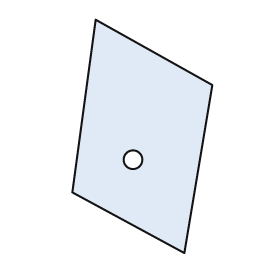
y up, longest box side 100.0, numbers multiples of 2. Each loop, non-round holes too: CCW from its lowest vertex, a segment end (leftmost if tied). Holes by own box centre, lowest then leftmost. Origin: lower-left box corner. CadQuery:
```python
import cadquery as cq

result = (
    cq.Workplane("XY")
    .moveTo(48.0, 0.0)
    .lineTo(60.0, 72.0)
    .lineTo(10.0, 100.0)
    .lineTo(0.0, 26.0)
    .close()
    .moveTo(26.0, 40.0)
    .circle(4.0)
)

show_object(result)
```